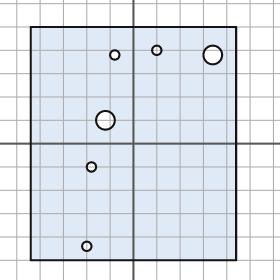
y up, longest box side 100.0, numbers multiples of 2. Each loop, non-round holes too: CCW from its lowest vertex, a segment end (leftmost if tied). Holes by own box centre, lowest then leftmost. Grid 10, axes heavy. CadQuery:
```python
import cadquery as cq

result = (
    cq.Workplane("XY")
    .moveTo(-44.0, -50.0)
    .lineTo(44.0, -50.0)
    .lineTo(44.0, 50.0)
    .lineTo(-44.0, 50.0)
    .close()
    .moveTo(-20.0, -44.0)
    .circle(2.0)
    .moveTo(-18.0, -10.0)
    .circle(2.0)
    .moveTo(-12.0, 10.0)
    .circle(4.0)
    .moveTo(-8.0, 38.0)
    .circle(2.0)
    .moveTo(34.0, 38.0)
    .circle(4.0)
    .moveTo(10.0, 40.0)
    .circle(2.0)
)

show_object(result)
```